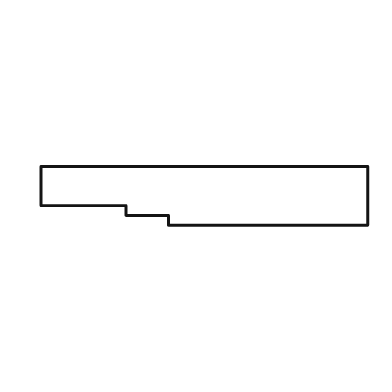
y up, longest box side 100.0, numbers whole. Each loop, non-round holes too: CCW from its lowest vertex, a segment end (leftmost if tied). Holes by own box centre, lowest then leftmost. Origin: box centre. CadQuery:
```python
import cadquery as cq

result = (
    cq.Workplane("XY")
    .moveTo(-11.0, -9.0)
    .lineTo(50.0, -9.0)
    .lineTo(50.0, 9.0)
    .lineTo(-50.0, 9.0)
    .lineTo(-50.0, -3.0)
    .lineTo(-24.0, -3.0)
    .lineTo(-24.0, -6.0)
    .lineTo(-11.0, -6.0)
    .close()
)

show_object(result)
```